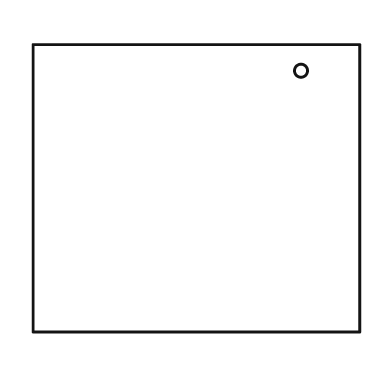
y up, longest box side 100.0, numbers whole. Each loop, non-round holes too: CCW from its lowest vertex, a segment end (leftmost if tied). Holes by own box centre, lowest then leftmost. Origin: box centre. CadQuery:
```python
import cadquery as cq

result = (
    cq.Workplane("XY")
    .moveTo(-50.0, -44.0)
    .lineTo(50.0, -44.0)
    .lineTo(50.0, 44.0)
    .lineTo(-50.0, 44.0)
    .close()
    .moveTo(32.0, 36.0)
    .circle(2.0)
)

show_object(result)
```